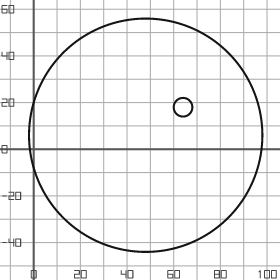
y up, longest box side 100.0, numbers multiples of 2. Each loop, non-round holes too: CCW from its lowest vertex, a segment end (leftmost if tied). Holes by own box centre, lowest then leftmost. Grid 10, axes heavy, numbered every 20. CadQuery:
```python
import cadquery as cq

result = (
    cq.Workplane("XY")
    .moveTo(48.0, 6.0)
    .circle(50.0)
    .moveTo(64.0, 18.0)
    .circle(4.0)
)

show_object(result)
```